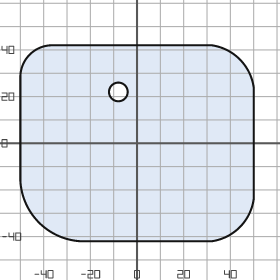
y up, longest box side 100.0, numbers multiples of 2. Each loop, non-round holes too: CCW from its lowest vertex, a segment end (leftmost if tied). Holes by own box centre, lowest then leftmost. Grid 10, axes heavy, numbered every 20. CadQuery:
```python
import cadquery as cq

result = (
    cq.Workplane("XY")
    .moveTo(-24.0, -42.0)
    .lineTo(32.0, -42.0)
    .threePointArc((44.0, -36.0), (50.0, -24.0))
    .lineTo(50.0, 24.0)
    .threePointArc((44.0, 36.0), (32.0, 42.0))
    .lineTo(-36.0, 42.0)
    .threePointArc((-46.0, 38.0), (-50.0, 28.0))
    .lineTo(-50.0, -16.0)
    .threePointArc((-42.0, -34.0), (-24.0, -42.0))
    .close()
    .moveTo(-8.0, 22.0)
    .circle(4.0)
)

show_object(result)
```